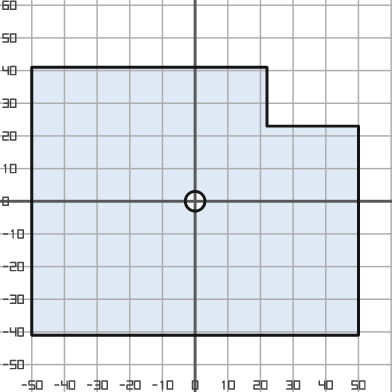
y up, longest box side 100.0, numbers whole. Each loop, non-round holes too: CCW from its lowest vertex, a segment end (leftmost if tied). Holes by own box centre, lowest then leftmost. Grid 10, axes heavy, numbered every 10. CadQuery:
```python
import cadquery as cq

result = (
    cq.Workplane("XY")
    .moveTo(-50.0, -41.0)
    .lineTo(50.0, -41.0)
    .lineTo(50.0, 23.0)
    .lineTo(22.0, 23.0)
    .lineTo(22.0, 41.0)
    .lineTo(-50.0, 41.0)
    .close()
    .moveTo(0.0, 0.0)
    .circle(3.0)
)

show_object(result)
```